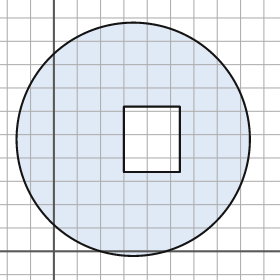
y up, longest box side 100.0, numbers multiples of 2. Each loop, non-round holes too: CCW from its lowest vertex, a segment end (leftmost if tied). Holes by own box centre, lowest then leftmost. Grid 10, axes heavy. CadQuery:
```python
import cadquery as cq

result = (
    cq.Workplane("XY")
    .moveTo(34.0, 48.0)
    .circle(50.0)
    .moveTo(30.0, 34.0)
    .lineTo(54.0, 34.0)
    .lineTo(54.0, 62.0)
    .lineTo(30.0, 62.0)
    .close()
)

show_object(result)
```